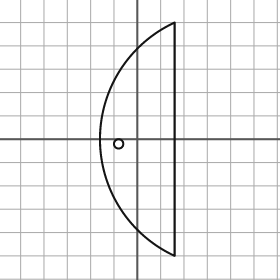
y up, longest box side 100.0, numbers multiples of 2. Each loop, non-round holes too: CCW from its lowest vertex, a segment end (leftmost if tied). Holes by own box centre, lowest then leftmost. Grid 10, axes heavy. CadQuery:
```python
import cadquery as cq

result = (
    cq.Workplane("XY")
    .moveTo(16.0, -50.0)
    .lineTo(16.0, 50.0)
    .threePointArc((-16.0, 0.0), (16.0, -50.0))
    .close()
    .moveTo(-8.0, -2.0)
    .circle(2.0)
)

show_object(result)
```